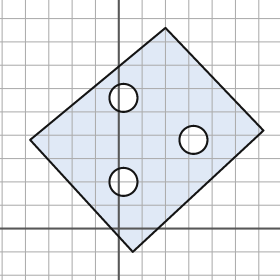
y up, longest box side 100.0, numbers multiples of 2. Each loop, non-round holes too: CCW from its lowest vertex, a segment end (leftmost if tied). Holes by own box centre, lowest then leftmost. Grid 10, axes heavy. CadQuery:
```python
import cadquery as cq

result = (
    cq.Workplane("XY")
    .moveTo(6.0, -10.0)
    .lineTo(62.0, 42.0)
    .lineTo(20.0, 86.0)
    .lineTo(-38.0, 38.0)
    .close()
    .moveTo(2.0, 20.0)
    .circle(6.0)
    .moveTo(32.0, 38.0)
    .circle(6.0)
    .moveTo(2.0, 56.0)
    .circle(6.0)
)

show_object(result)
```